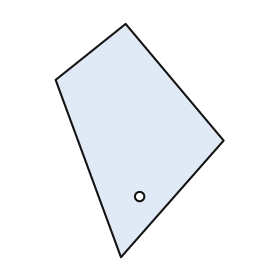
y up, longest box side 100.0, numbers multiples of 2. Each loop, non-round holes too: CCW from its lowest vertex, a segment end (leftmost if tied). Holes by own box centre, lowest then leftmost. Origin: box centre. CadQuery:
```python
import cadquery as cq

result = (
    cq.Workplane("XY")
    .moveTo(-8.0, -50.0)
    .lineTo(36.0, 0.0)
    .lineTo(-6.0, 50.0)
    .lineTo(-36.0, 26.0)
    .close()
    .moveTo(0.0, -24.0)
    .circle(2.0)
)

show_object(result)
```